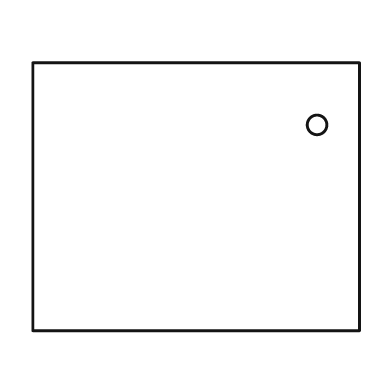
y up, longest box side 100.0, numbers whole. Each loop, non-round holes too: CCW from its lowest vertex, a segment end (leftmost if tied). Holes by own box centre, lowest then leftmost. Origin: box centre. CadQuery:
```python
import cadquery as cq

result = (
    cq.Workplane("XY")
    .moveTo(-50.0, -41.0)
    .lineTo(50.0, -41.0)
    .lineTo(50.0, 41.0)
    .lineTo(-50.0, 41.0)
    .close()
    .moveTo(37.0, 22.0)
    .circle(3.0)
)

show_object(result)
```